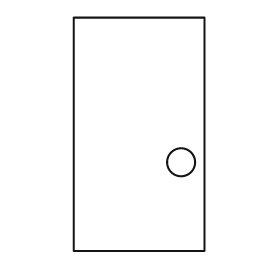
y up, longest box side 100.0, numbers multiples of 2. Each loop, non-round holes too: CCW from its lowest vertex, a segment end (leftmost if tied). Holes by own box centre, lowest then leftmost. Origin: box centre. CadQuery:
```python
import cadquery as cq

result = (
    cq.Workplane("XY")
    .moveTo(-28.0, -50.0)
    .lineTo(28.0, -50.0)
    .lineTo(28.0, 50.0)
    .lineTo(-28.0, 50.0)
    .close()
    .moveTo(18.0, -12.0)
    .circle(6.0)
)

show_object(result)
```